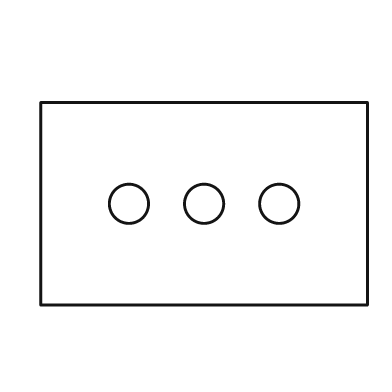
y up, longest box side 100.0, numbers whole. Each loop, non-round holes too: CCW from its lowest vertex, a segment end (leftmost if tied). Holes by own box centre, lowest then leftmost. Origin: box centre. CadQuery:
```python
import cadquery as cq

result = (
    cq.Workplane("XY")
    .moveTo(-50.0, -31.0)
    .lineTo(50.0, -31.0)
    .lineTo(50.0, 31.0)
    .lineTo(-50.0, 31.0)
    .close()
    .moveTo(-23.0, 0.0)
    .circle(6.0)
    .moveTo(0.0, 0.0)
    .circle(6.0)
    .moveTo(23.0, 0.0)
    .circle(6.0)
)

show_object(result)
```